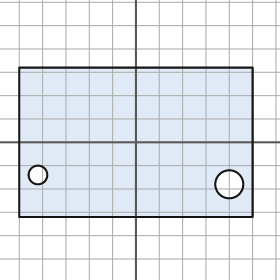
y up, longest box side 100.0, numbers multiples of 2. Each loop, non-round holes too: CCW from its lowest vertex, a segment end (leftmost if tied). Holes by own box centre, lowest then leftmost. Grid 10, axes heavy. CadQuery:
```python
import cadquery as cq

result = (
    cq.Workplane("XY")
    .moveTo(-50.0, -32.0)
    .lineTo(50.0, -32.0)
    .lineTo(50.0, 32.0)
    .lineTo(-50.0, 32.0)
    .close()
    .moveTo(40.0, -18.0)
    .circle(6.0)
    .moveTo(-42.0, -14.0)
    .circle(4.0)
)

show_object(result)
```